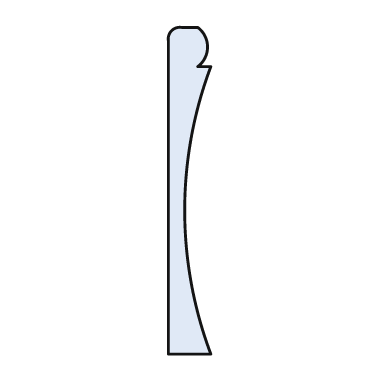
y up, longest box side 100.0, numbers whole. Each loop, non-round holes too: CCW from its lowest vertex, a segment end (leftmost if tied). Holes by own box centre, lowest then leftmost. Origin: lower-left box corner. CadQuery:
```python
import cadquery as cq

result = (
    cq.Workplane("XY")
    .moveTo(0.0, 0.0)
    .lineTo(13.0, 0.0)
    .threePointArc((5.0, 44.0), (13.0, 88.0))
    .lineTo(9.0, 88.0)
    .threePointArc((12.0, 94.0), (9.0, 100.0))
    .lineTo(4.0, 100.0)
    .threePointArc((1.0, 99.0), (0.0, 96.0))
    .close()
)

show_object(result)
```